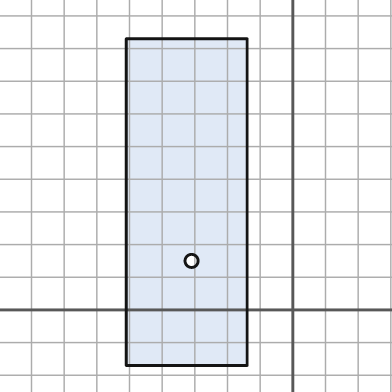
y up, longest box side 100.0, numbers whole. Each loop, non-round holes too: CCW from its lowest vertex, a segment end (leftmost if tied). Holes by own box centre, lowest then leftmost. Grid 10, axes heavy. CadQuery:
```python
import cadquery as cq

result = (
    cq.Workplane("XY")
    .moveTo(-51.0, -17.0)
    .lineTo(-14.0, -17.0)
    .lineTo(-14.0, 83.0)
    .lineTo(-51.0, 83.0)
    .close()
    .moveTo(-31.0, 15.0)
    .circle(2.0)
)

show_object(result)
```